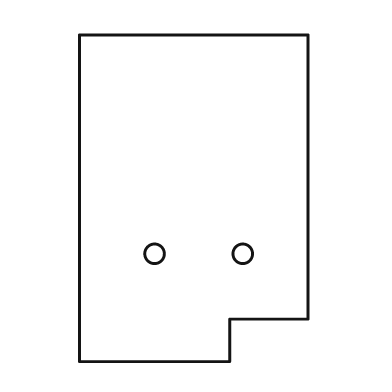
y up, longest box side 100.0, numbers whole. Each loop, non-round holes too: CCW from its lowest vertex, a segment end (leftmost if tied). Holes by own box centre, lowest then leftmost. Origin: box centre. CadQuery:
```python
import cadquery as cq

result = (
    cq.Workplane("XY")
    .moveTo(-35.0, -50.0)
    .lineTo(11.0, -50.0)
    .lineTo(11.0, -37.0)
    .lineTo(35.0, -37.0)
    .lineTo(35.0, 50.0)
    .lineTo(-35.0, 50.0)
    .close()
    .moveTo(-12.0, -17.0)
    .circle(3.0)
    .moveTo(15.0, -17.0)
    .circle(3.0)
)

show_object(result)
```